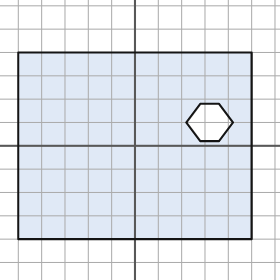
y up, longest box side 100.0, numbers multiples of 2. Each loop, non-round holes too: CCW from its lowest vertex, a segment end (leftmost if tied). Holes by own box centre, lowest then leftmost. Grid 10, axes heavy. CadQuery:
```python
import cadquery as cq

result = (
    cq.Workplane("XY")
    .moveTo(-50.0, -40.0)
    .lineTo(50.0, -40.0)
    .lineTo(50.0, 40.0)
    .lineTo(-50.0, 40.0)
    .close()
    .moveTo(28.0, 2.0)
    .lineTo(36.0, 2.0)
    .lineTo(42.0, 10.0)
    .lineTo(36.0, 18.0)
    .lineTo(28.0, 18.0)
    .lineTo(22.0, 10.0)
    .close()
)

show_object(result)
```